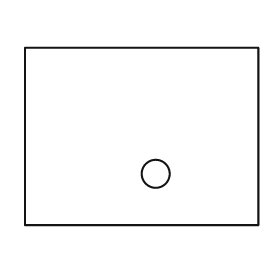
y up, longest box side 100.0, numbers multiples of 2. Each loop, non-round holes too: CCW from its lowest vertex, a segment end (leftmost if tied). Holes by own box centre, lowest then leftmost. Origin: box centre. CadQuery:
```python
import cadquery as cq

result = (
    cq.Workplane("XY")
    .moveTo(-50.0, -38.0)
    .lineTo(50.0, -38.0)
    .lineTo(50.0, 38.0)
    .lineTo(-50.0, 38.0)
    .close()
    .moveTo(6.0, -16.0)
    .circle(6.0)
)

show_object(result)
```